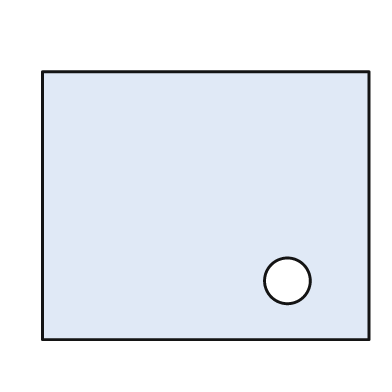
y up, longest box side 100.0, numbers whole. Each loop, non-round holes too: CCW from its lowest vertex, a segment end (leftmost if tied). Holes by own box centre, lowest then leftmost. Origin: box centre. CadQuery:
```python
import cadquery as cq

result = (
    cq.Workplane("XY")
    .moveTo(-50.0, -41.0)
    .lineTo(50.0, -41.0)
    .lineTo(50.0, 41.0)
    .lineTo(-50.0, 41.0)
    .close()
    .moveTo(25.0, -23.0)
    .circle(7.0)
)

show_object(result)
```